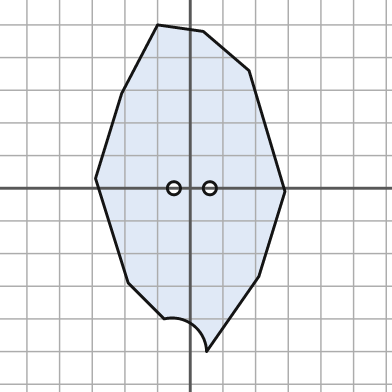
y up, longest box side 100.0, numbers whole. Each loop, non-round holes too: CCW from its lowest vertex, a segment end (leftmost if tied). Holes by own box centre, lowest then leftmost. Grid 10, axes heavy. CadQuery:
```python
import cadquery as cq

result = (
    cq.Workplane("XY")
    .moveTo(5.0, -50.0)
    .lineTo(21.0, -27.0)
    .lineTo(29.0, -1.0)
    .lineTo(18.0, 36.0)
    .lineTo(4.0, 48.0)
    .lineTo(-10.0, 50.0)
    .lineTo(-21.0, 29.0)
    .lineTo(-29.0, 3.0)
    .lineTo(-19.0, -29.0)
    .lineTo(-8.0, -40.0)
    .threePointArc((1.0, -42.0), (5.0, -50.0))
    .close()
    .moveTo(-5.0, 0.0)
    .circle(2.0)
    .moveTo(6.0, 0.0)
    .circle(2.0)
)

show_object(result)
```